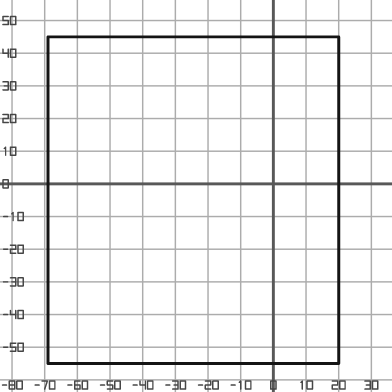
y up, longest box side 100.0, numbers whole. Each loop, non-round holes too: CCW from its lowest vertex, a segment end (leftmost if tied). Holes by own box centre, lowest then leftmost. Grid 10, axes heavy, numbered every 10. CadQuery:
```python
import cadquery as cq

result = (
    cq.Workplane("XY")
    .moveTo(-69.0, -55.0)
    .lineTo(20.0, -55.0)
    .lineTo(20.0, 45.0)
    .lineTo(-69.0, 45.0)
    .close()
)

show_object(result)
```